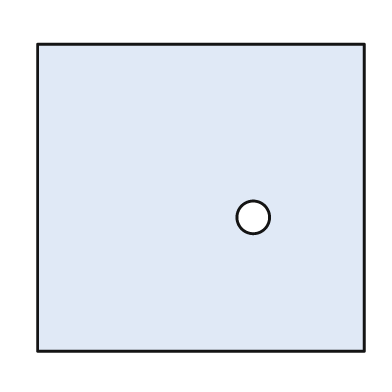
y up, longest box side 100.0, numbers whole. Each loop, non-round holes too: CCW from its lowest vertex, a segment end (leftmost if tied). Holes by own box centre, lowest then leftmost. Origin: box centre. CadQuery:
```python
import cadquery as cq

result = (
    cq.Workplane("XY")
    .moveTo(-50.0, -47.0)
    .lineTo(50.0, -47.0)
    .lineTo(50.0, 47.0)
    .lineTo(-50.0, 47.0)
    .close()
    .moveTo(16.0, -6.0)
    .circle(5.0)
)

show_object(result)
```